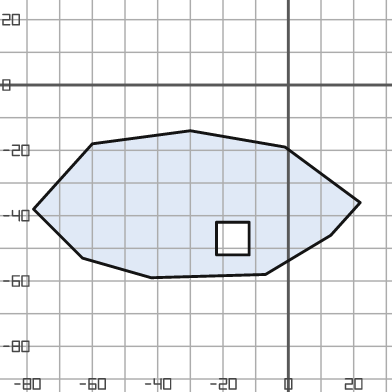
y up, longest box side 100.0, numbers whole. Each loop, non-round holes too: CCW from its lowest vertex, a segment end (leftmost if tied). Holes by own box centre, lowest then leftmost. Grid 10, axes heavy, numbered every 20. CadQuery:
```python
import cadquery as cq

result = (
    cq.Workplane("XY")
    .moveTo(-42.0, -59.0)
    .lineTo(-7.0, -58.0)
    .lineTo(13.0, -46.0)
    .lineTo(22.0, -36.0)
    .lineTo(-1.0, -19.0)
    .lineTo(-30.0, -14.0)
    .lineTo(-60.0, -18.0)
    .lineTo(-78.0, -38.0)
    .lineTo(-63.0, -53.0)
    .close()
    .moveTo(-22.0, -52.0)
    .lineTo(-12.0, -52.0)
    .lineTo(-12.0, -42.0)
    .lineTo(-22.0, -42.0)
    .close()
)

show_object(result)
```